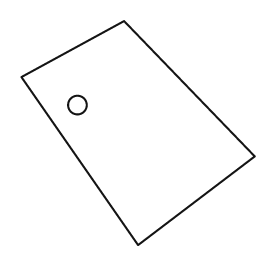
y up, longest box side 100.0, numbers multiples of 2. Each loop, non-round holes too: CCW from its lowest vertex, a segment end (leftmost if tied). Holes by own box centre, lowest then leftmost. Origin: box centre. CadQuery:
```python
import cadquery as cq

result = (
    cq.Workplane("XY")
    .moveTo(0.0, -48.0)
    .lineTo(50.0, -10.0)
    .lineTo(-6.0, 48.0)
    .lineTo(-50.0, 24.0)
    .close()
    .moveTo(-26.0, 12.0)
    .circle(4.0)
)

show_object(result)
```